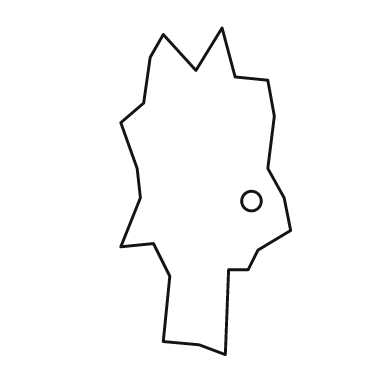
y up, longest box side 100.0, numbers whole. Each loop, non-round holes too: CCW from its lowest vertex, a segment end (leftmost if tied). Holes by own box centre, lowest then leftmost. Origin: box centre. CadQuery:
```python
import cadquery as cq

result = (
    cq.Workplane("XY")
    .moveTo(6.0, -50.0)
    .lineTo(7.0, -24.0)
    .lineTo(13.0, -24.0)
    .lineTo(16.0, -18.0)
    .lineTo(26.0, -12.0)
    .lineTo(24.0, -2.0)
    .lineTo(19.0, 7.0)
    .lineTo(21.0, 23.0)
    .lineTo(19.0, 34.0)
    .lineTo(9.0, 35.0)
    .lineTo(5.0, 50.0)
    .lineTo(-3.0, 37.0)
    .lineTo(-13.0, 48.0)
    .lineTo(-17.0, 41.0)
    .lineTo(-19.0, 27.0)
    .lineTo(-26.0, 21.0)
    .lineTo(-21.0, 7.0)
    .lineTo(-20.0, -2.0)
    .lineTo(-26.0, -17.0)
    .lineTo(-16.0, -16.0)
    .lineTo(-11.0, -26.0)
    .lineTo(-13.0, -46.0)
    .lineTo(-2.0, -47.0)
    .close()
    .moveTo(14.0, -3.0)
    .circle(3.0)
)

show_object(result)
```